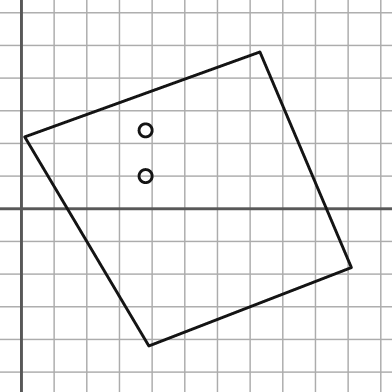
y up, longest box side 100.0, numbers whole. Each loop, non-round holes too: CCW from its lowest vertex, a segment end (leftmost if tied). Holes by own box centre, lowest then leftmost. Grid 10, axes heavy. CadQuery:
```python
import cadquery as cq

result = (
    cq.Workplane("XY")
    .moveTo(39.0, -42.0)
    .lineTo(101.0, -18.0)
    .lineTo(73.0, 48.0)
    .lineTo(1.0, 22.0)
    .close()
    .moveTo(38.0, 10.0)
    .circle(2.0)
    .moveTo(38.0, 24.0)
    .circle(2.0)
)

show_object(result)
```